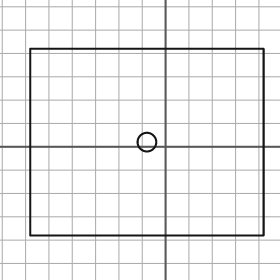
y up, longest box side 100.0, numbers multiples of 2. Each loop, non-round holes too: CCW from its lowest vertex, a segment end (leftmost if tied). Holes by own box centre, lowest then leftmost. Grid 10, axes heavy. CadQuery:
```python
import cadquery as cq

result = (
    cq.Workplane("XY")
    .moveTo(-58.0, -38.0)
    .lineTo(42.0, -38.0)
    .lineTo(42.0, 42.0)
    .lineTo(-58.0, 42.0)
    .close()
    .moveTo(-8.0, 2.0)
    .circle(4.0)
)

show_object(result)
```